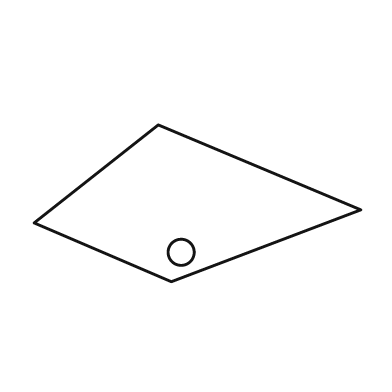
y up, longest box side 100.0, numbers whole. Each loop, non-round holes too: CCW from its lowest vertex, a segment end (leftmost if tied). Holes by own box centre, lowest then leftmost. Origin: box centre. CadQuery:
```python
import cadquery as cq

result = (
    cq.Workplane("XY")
    .moveTo(-8.0, -24.0)
    .lineTo(50.0, -2.0)
    .lineTo(-12.0, 24.0)
    .lineTo(-50.0, -6.0)
    .close()
    .moveTo(-5.0, -15.0)
    .circle(4.0)
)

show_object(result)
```